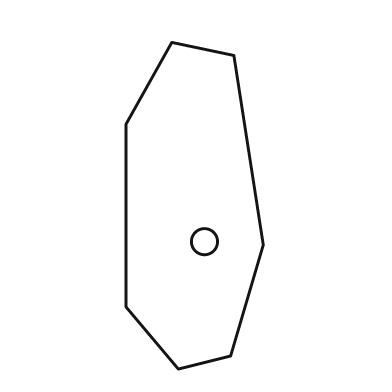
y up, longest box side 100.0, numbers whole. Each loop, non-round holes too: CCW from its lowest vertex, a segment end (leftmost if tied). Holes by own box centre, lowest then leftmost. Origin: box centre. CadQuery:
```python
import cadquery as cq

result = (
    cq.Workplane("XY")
    .moveTo(-5.0, -50.0)
    .lineTo(11.0, -46.0)
    .lineTo(21.0, -12.0)
    .lineTo(12.0, 46.0)
    .lineTo(-7.0, 50.0)
    .lineTo(-21.0, 25.0)
    .lineTo(-21.0, -31.0)
    .close()
    .moveTo(3.0, -11.0)
    .circle(4.0)
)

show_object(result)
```